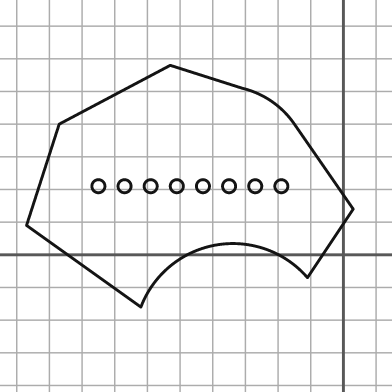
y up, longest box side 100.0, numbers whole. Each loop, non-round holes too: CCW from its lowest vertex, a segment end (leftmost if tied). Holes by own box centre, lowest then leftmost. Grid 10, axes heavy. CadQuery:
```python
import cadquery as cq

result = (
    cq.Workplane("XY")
    .moveTo(-62.0, -16.0)
    .threePointArc((-39.0, 3.0), (-11.0, -7.0))
    .lineTo(3.0, 14.0)
    .lineTo(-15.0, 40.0)
    .threePointArc((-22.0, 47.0), (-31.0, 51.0))
    .lineTo(-53.0, 58.0)
    .lineTo(-87.0, 40.0)
    .lineTo(-97.0, 9.0)
    .close()
    .moveTo(-75.0, 21.0)
    .circle(2.0)
    .moveTo(-67.0, 21.0)
    .circle(2.0)
    .moveTo(-59.0, 21.0)
    .circle(2.0)
    .moveTo(-51.0, 21.0)
    .circle(2.0)
    .moveTo(-43.0, 21.0)
    .circle(2.0)
    .moveTo(-35.0, 21.0)
    .circle(2.0)
    .moveTo(-27.0, 21.0)
    .circle(2.0)
    .moveTo(-19.0, 21.0)
    .circle(2.0)
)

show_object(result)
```